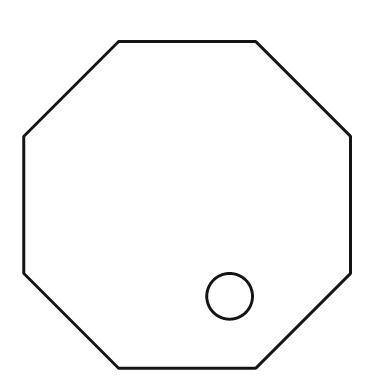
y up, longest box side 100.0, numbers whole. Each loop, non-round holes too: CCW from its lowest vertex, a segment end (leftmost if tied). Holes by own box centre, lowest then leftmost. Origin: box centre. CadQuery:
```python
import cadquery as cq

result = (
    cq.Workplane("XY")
    .moveTo(-21.0, -50.0)
    .lineTo(21.0, -50.0)
    .lineTo(50.0, -21.0)
    .lineTo(50.0, 21.0)
    .lineTo(21.0, 50.0)
    .lineTo(-21.0, 50.0)
    .lineTo(-50.0, 21.0)
    .lineTo(-50.0, -21.0)
    .close()
    .moveTo(13.0, -28.0)
    .circle(7.0)
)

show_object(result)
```